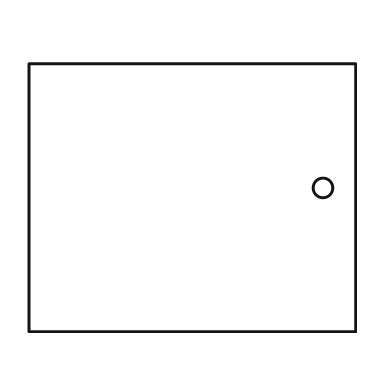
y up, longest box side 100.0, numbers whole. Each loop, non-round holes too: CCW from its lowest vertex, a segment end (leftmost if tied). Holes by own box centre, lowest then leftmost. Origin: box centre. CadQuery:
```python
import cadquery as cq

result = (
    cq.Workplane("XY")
    .moveTo(-50.0, -41.0)
    .lineTo(50.0, -41.0)
    .lineTo(50.0, 41.0)
    .lineTo(-50.0, 41.0)
    .close()
    .moveTo(40.0, 3.0)
    .circle(3.0)
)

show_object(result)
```